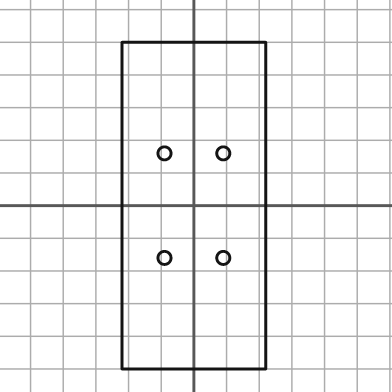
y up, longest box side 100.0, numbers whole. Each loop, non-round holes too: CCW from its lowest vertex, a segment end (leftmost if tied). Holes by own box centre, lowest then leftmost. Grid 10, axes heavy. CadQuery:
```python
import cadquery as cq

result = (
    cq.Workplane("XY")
    .moveTo(-22.0, -50.0)
    .lineTo(22.0, -50.0)
    .lineTo(22.0, 50.0)
    .lineTo(-22.0, 50.0)
    .close()
    .moveTo(-9.0, -16.0)
    .circle(2.0)
    .moveTo(9.0, -16.0)
    .circle(2.0)
    .moveTo(-9.0, 16.0)
    .circle(2.0)
    .moveTo(9.0, 16.0)
    .circle(2.0)
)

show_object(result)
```